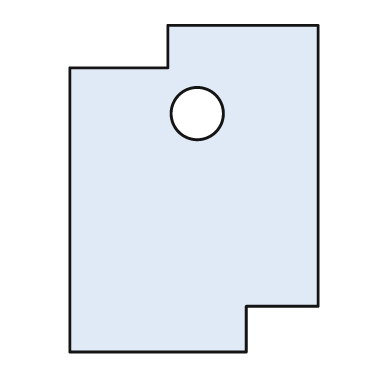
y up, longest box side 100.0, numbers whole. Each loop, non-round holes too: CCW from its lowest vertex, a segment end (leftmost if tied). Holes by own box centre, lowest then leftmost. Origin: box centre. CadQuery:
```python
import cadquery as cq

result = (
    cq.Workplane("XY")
    .moveTo(-38.0, -50.0)
    .lineTo(16.0, -50.0)
    .lineTo(16.0, -36.0)
    .lineTo(38.0, -36.0)
    .lineTo(38.0, 50.0)
    .lineTo(-8.0, 50.0)
    .lineTo(-8.0, 37.0)
    .lineTo(-38.0, 37.0)
    .close()
    .moveTo(1.0, 23.0)
    .circle(8.0)
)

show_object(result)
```